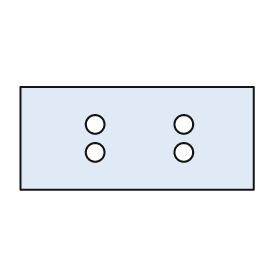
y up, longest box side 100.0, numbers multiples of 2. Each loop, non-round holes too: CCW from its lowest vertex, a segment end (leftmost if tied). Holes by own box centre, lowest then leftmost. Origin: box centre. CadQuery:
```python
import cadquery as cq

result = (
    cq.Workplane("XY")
    .moveTo(-50.0, -22.0)
    .lineTo(50.0, -22.0)
    .lineTo(50.0, 22.0)
    .lineTo(-50.0, 22.0)
    .close()
    .moveTo(-18.0, -6.0)
    .circle(4.0)
    .moveTo(20.0, -6.0)
    .circle(4.0)
    .moveTo(-18.0, 6.0)
    .circle(4.0)
    .moveTo(20.0, 6.0)
    .circle(4.0)
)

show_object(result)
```